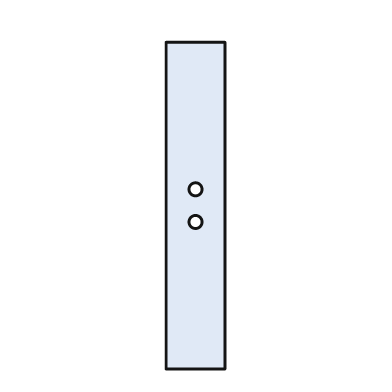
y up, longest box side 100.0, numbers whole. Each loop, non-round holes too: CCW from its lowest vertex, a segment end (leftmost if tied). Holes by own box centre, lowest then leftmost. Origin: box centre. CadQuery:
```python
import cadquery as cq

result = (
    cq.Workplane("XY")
    .moveTo(-9.0, -50.0)
    .lineTo(9.0, -50.0)
    .lineTo(9.0, 50.0)
    .lineTo(-9.0, 50.0)
    .close()
    .moveTo(0.0, -5.0)
    .circle(2.0)
    .moveTo(0.0, 5.0)
    .circle(2.0)
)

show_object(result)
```